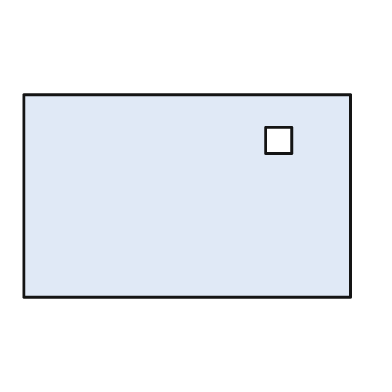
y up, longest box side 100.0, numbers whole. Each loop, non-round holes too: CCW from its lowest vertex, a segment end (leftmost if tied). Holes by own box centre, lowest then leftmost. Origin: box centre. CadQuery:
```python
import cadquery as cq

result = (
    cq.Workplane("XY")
    .moveTo(-50.0, -31.0)
    .lineTo(50.0, -31.0)
    .lineTo(50.0, 31.0)
    .lineTo(-50.0, 31.0)
    .close()
    .moveTo(24.0, 13.0)
    .lineTo(32.0, 13.0)
    .lineTo(32.0, 21.0)
    .lineTo(24.0, 21.0)
    .close()
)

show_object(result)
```